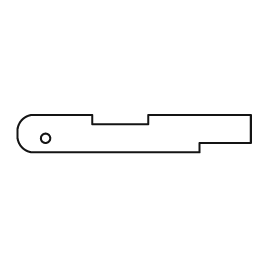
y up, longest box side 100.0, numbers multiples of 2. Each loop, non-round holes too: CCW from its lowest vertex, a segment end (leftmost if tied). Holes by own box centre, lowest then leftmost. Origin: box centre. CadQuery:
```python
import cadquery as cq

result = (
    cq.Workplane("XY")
    .moveTo(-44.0, -8.0)
    .lineTo(28.0, -8.0)
    .lineTo(28.0, -4.0)
    .lineTo(50.0, -4.0)
    .lineTo(50.0, 8.0)
    .lineTo(6.0, 8.0)
    .lineTo(6.0, 4.0)
    .lineTo(-18.0, 4.0)
    .lineTo(-18.0, 8.0)
    .lineTo(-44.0, 8.0)
    .threePointArc((-48.0, 6.0), (-50.0, 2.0))
    .lineTo(-50.0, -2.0)
    .threePointArc((-48.0, -6.0), (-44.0, -8.0))
    .close()
    .moveTo(-38.0, -2.0)
    .circle(2.0)
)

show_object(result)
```